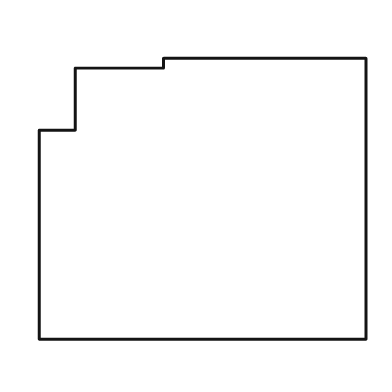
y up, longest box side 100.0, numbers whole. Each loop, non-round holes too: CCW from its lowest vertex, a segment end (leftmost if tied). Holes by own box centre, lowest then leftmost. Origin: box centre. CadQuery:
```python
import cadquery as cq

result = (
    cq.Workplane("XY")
    .moveTo(-50.0, -43.0)
    .lineTo(50.0, -43.0)
    .lineTo(50.0, 43.0)
    .lineTo(-12.0, 43.0)
    .lineTo(-12.0, 40.0)
    .lineTo(-39.0, 40.0)
    .lineTo(-39.0, 21.0)
    .lineTo(-50.0, 21.0)
    .close()
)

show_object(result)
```